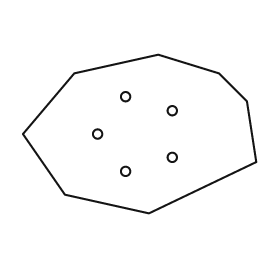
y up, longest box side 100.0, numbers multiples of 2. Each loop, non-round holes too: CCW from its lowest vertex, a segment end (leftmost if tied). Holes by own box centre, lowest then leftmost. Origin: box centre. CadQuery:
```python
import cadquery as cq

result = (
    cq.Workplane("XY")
    .moveTo(4.0, -34.0)
    .lineTo(50.0, -12.0)
    .lineTo(46.0, 14.0)
    .lineTo(34.0, 26.0)
    .lineTo(8.0, 34.0)
    .lineTo(-28.0, 26.0)
    .lineTo(-50.0, 0.0)
    .lineTo(-32.0, -26.0)
    .close()
    .moveTo(-6.0, -16.0)
    .circle(2.0)
    .moveTo(14.0, -10.0)
    .circle(2.0)
    .moveTo(-18.0, 0.0)
    .circle(2.0)
    .moveTo(14.0, 10.0)
    .circle(2.0)
    .moveTo(-6.0, 16.0)
    .circle(2.0)
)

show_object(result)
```